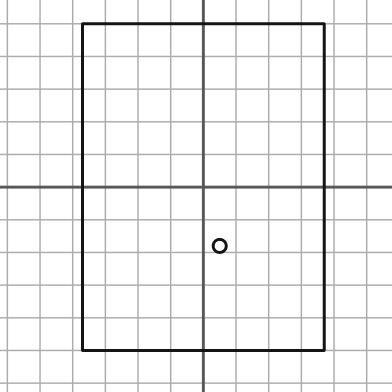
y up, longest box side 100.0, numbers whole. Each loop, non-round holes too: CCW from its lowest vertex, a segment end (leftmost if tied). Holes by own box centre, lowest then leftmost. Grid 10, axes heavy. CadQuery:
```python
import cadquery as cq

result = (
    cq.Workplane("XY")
    .moveTo(-37.0, -50.0)
    .lineTo(37.0, -50.0)
    .lineTo(37.0, 50.0)
    .lineTo(-37.0, 50.0)
    .close()
    .moveTo(5.0, -18.0)
    .circle(2.0)
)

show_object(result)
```